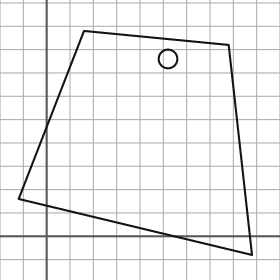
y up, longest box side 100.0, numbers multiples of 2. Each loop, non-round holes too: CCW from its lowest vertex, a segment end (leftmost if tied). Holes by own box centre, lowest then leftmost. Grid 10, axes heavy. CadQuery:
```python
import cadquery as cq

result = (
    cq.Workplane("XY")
    .moveTo(88.0, -8.0)
    .lineTo(78.0, 82.0)
    .lineTo(16.0, 88.0)
    .lineTo(-12.0, 16.0)
    .close()
    .moveTo(52.0, 76.0)
    .circle(4.0)
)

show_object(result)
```